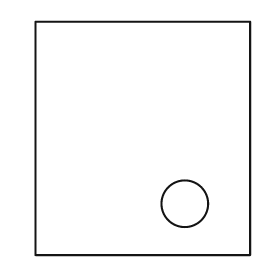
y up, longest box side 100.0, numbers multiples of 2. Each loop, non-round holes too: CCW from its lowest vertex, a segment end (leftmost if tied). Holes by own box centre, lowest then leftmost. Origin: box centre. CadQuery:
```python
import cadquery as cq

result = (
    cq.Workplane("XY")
    .moveTo(-46.0, -50.0)
    .lineTo(46.0, -50.0)
    .lineTo(46.0, 50.0)
    .lineTo(-46.0, 50.0)
    .close()
    .moveTo(18.0, -28.0)
    .circle(10.0)
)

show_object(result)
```